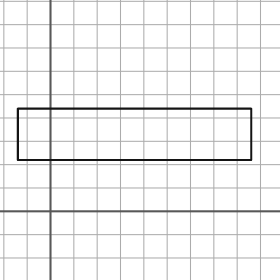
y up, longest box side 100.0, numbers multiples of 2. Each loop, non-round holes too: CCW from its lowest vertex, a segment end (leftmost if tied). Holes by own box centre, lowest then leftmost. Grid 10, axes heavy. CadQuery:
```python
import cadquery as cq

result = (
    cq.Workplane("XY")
    .moveTo(-14.0, 22.0)
    .lineTo(86.0, 22.0)
    .lineTo(86.0, 44.0)
    .lineTo(-14.0, 44.0)
    .close()
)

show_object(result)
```